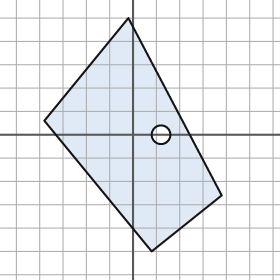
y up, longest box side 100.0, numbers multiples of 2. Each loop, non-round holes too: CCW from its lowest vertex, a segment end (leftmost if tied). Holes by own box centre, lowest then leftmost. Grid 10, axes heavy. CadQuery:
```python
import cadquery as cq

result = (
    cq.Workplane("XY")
    .moveTo(8.0, -50.0)
    .lineTo(38.0, -26.0)
    .lineTo(-2.0, 50.0)
    .lineTo(-38.0, 6.0)
    .close()
    .moveTo(12.0, 0.0)
    .circle(4.0)
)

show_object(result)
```